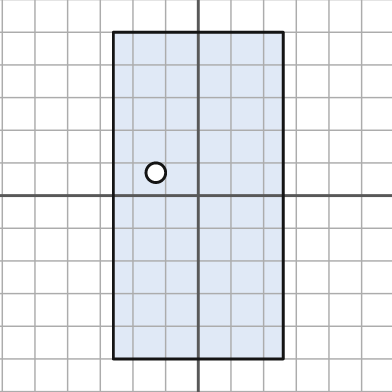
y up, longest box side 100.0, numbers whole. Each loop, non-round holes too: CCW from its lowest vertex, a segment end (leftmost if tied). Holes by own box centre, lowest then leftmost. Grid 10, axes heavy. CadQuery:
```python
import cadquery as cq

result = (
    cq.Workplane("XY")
    .moveTo(-26.0, -50.0)
    .lineTo(26.0, -50.0)
    .lineTo(26.0, 50.0)
    .lineTo(-26.0, 50.0)
    .close()
    .moveTo(-13.0, 7.0)
    .circle(3.0)
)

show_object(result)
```